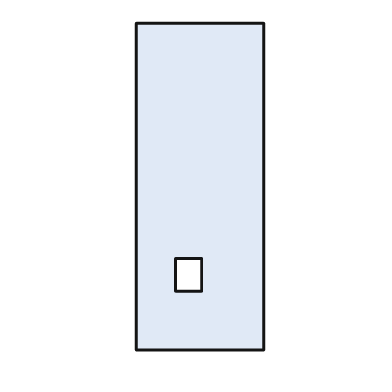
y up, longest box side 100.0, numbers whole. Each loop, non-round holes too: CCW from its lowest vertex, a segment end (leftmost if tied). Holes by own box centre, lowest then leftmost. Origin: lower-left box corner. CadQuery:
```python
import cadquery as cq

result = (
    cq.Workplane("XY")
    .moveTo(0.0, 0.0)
    .lineTo(39.0, 0.0)
    .lineTo(39.0, 100.0)
    .lineTo(0.0, 100.0)
    .close()
    .moveTo(12.0, 18.0)
    .lineTo(20.0, 18.0)
    .lineTo(20.0, 28.0)
    .lineTo(12.0, 28.0)
    .close()
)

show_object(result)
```